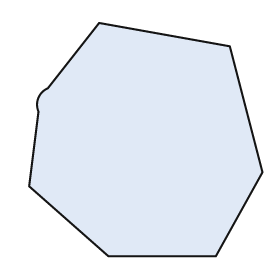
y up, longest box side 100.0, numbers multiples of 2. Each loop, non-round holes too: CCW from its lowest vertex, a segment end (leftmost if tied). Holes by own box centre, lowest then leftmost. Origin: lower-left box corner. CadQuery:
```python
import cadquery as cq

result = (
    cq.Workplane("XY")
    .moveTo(34.0, 0.0)
    .lineTo(80.0, 0.0)
    .lineTo(100.0, 36.0)
    .lineTo(86.0, 90.0)
    .lineTo(30.0, 100.0)
    .lineTo(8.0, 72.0)
    .threePointArc((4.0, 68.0), (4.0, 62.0))
    .lineTo(0.0, 30.0)
    .close()
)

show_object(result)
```